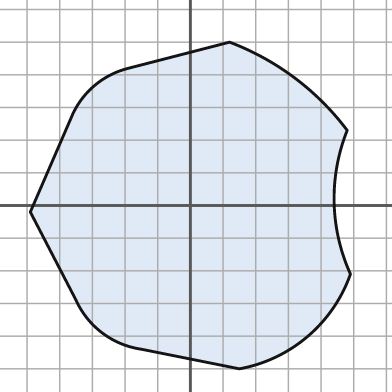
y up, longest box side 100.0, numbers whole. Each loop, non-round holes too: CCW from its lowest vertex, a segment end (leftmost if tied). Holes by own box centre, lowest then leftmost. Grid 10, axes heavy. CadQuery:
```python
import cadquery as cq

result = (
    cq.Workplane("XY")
    .moveTo(15.0, -50.0)
    .threePointArc((36.0, -40.0), (49.0, -21.0))
    .threePointArc((44.0, 1.0), (48.0, 23.0))
    .threePointArc((32.0, 39.0), (12.0, 50.0))
    .lineTo(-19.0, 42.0)
    .threePointArc((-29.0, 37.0), (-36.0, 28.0))
    .lineTo(-49.0, -2.0)
    .lineTo(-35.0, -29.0)
    .threePointArc((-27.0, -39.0), (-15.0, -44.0))
    .close()
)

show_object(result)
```